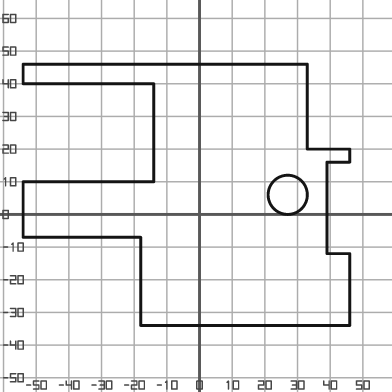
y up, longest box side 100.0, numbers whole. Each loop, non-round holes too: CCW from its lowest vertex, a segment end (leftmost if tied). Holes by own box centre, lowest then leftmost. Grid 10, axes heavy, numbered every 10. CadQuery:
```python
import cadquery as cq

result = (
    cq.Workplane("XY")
    .moveTo(-18.0, -34.0)
    .lineTo(46.0, -34.0)
    .lineTo(46.0, -12.0)
    .lineTo(39.0, -12.0)
    .lineTo(39.0, 16.0)
    .lineTo(46.0, 16.0)
    .lineTo(46.0, 20.0)
    .lineTo(33.0, 20.0)
    .lineTo(33.0, 46.0)
    .lineTo(-54.0, 46.0)
    .lineTo(-54.0, 40.0)
    .lineTo(-14.0, 40.0)
    .lineTo(-14.0, 10.0)
    .lineTo(-54.0, 10.0)
    .lineTo(-54.0, -7.0)
    .lineTo(-18.0, -7.0)
    .close()
    .moveTo(27.0, 6.0)
    .circle(6.0)
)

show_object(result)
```